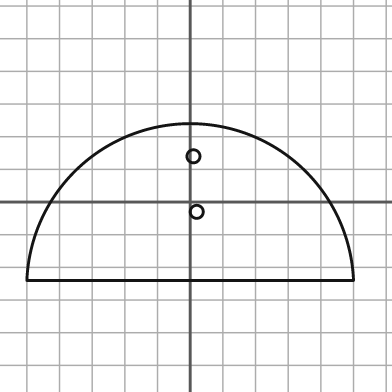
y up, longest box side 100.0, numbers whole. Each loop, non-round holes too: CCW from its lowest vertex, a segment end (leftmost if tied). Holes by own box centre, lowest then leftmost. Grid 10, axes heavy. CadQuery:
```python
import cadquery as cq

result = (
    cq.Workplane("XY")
    .moveTo(-50.0, -24.0)
    .lineTo(50.0, -24.0)
    .threePointArc((0.0, 24.0), (-50.0, -24.0))
    .close()
    .moveTo(2.0, -3.0)
    .circle(2.0)
    .moveTo(1.0, 14.0)
    .circle(2.0)
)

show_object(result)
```